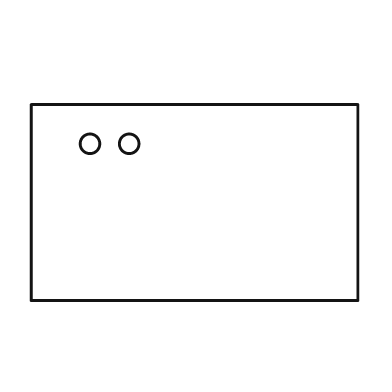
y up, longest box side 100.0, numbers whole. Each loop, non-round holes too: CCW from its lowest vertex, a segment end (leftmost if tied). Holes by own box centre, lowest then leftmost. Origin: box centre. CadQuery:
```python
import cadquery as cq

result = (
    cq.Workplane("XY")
    .moveTo(-50.0, -30.0)
    .lineTo(50.0, -30.0)
    .lineTo(50.0, 30.0)
    .lineTo(-50.0, 30.0)
    .close()
    .moveTo(-32.0, 18.0)
    .circle(3.0)
    .moveTo(-20.0, 18.0)
    .circle(3.0)
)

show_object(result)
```